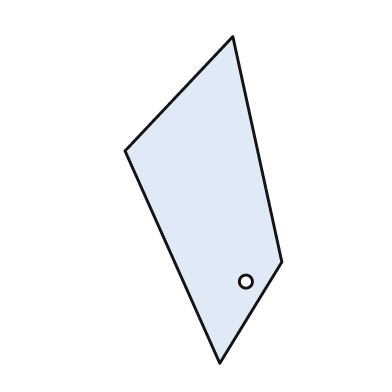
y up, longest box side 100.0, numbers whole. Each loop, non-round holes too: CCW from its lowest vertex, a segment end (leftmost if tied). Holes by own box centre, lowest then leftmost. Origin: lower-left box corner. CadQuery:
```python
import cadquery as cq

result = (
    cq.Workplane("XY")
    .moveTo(29.0, 0.0)
    .lineTo(48.0, 31.0)
    .lineTo(33.0, 100.0)
    .lineTo(0.0, 65.0)
    .close()
    .moveTo(37.0, 25.0)
    .circle(2.0)
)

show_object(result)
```